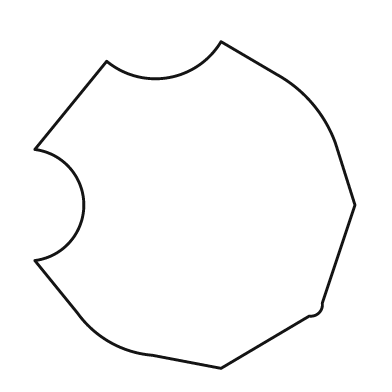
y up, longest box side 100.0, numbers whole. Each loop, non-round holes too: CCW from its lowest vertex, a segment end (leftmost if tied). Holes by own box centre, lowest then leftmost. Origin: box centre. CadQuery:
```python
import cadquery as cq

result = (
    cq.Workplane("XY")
    .moveTo(8.0, -50.0)
    .lineTo(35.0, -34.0)
    .threePointArc((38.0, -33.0), (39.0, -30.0))
    .lineTo(49.0, 0.0)
    .lineTo(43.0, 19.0)
    .threePointArc((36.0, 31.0), (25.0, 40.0))
    .lineTo(8.0, 50.0)
    .threePointArc((-8.0, 39.0), (-27.0, 44.0))
    .lineTo(-49.0, 17.0)
    .threePointArc((-34.0, 0.0), (-49.0, -17.0))
    .lineTo(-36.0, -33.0)
    .threePointArc((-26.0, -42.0), (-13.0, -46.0))
    .close()
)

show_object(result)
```